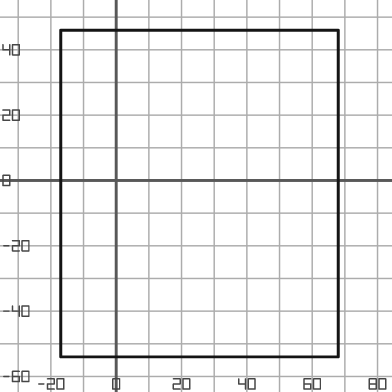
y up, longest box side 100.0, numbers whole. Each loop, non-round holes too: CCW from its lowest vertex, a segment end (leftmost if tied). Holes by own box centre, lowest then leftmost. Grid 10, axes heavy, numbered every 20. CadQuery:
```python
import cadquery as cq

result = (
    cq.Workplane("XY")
    .moveTo(-17.0, -54.0)
    .lineTo(68.0, -54.0)
    .lineTo(68.0, 46.0)
    .lineTo(-17.0, 46.0)
    .close()
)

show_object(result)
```